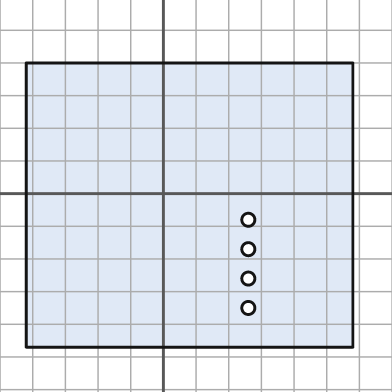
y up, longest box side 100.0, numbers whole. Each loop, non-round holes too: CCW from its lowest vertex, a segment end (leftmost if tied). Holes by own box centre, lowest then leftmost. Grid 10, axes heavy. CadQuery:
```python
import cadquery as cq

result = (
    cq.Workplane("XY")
    .moveTo(-42.0, -47.0)
    .lineTo(58.0, -47.0)
    .lineTo(58.0, 40.0)
    .lineTo(-42.0, 40.0)
    .close()
    .moveTo(26.0, -35.0)
    .circle(2.0)
    .moveTo(26.0, -26.0)
    .circle(2.0)
    .moveTo(26.0, -17.0)
    .circle(2.0)
    .moveTo(26.0, -8.0)
    .circle(2.0)
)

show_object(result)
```